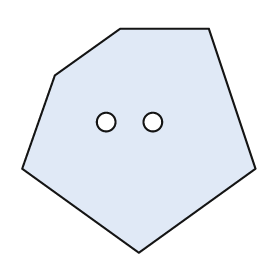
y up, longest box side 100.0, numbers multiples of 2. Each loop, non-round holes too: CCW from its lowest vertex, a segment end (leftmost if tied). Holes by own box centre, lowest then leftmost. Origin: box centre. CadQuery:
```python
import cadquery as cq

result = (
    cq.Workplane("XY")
    .moveTo(0.0, -48.0)
    .lineTo(50.0, -12.0)
    .lineTo(30.0, 48.0)
    .lineTo(-8.0, 48.0)
    .lineTo(-36.0, 28.0)
    .lineTo(-50.0, -12.0)
    .close()
    .moveTo(-14.0, 8.0)
    .circle(4.0)
    .moveTo(6.0, 8.0)
    .circle(4.0)
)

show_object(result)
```